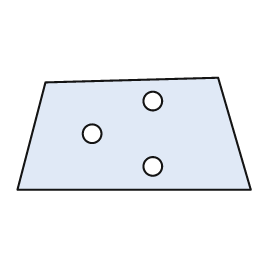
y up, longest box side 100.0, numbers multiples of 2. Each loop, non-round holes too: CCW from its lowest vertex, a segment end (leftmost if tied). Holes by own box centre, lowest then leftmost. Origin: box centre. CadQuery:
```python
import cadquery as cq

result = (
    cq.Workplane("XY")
    .moveTo(-50.0, -24.0)
    .lineTo(50.0, -24.0)
    .lineTo(36.0, 24.0)
    .lineTo(-38.0, 22.0)
    .close()
    .moveTo(8.0, -14.0)
    .circle(4.0)
    .moveTo(-18.0, 0.0)
    .circle(4.0)
    .moveTo(8.0, 14.0)
    .circle(4.0)
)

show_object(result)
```